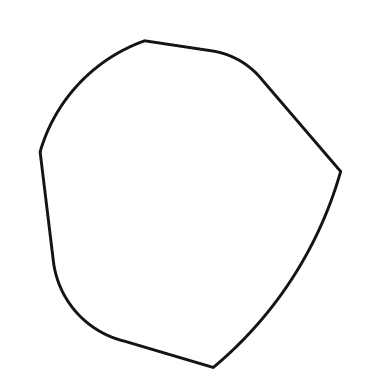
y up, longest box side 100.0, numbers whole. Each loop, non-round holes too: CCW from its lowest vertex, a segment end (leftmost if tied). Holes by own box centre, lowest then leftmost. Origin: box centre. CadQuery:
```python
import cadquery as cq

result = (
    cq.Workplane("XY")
    .moveTo(7.0, -50.0)
    .threePointArc((31.0, -23.0), (46.0, 10.0))
    .lineTo(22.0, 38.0)
    .threePointArc((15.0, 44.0), (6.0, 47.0))
    .lineTo(-14.0, 50.0)
    .threePointArc((-34.0, 37.0), (-46.0, 16.0))
    .lineTo(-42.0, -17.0)
    .threePointArc((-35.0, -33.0), (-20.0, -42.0))
    .close()
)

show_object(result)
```